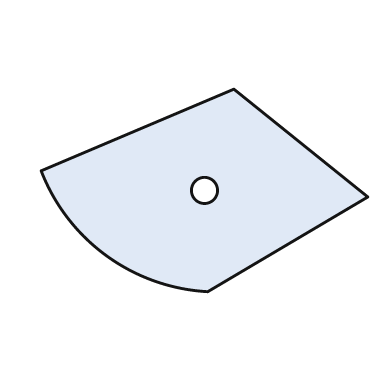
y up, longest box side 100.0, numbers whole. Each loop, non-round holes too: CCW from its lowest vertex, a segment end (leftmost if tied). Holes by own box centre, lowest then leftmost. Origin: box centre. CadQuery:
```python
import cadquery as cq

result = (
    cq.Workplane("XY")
    .moveTo(1.0, -31.0)
    .lineTo(50.0, -2.0)
    .lineTo(9.0, 31.0)
    .lineTo(-50.0, 6.0)
    .threePointArc((-30.0, -20.0), (1.0, -31.0))
    .close()
    .moveTo(0.0, 0.0)
    .circle(4.0)
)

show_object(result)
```